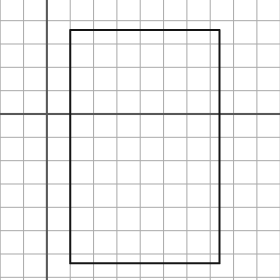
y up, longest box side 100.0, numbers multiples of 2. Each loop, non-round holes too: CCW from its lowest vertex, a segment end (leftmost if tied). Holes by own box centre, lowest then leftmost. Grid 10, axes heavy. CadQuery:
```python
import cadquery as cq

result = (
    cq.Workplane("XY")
    .moveTo(10.0, -64.0)
    .lineTo(74.0, -64.0)
    .lineTo(74.0, 36.0)
    .lineTo(10.0, 36.0)
    .close()
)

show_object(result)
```